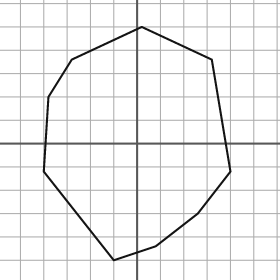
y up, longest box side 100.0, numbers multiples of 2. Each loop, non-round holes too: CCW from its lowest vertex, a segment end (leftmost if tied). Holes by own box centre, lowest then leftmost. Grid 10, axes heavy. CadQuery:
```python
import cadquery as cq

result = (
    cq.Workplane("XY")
    .moveTo(-10.0, -50.0)
    .lineTo(8.0, -44.0)
    .lineTo(26.0, -30.0)
    .lineTo(40.0, -12.0)
    .lineTo(32.0, 36.0)
    .lineTo(2.0, 50.0)
    .lineTo(-28.0, 36.0)
    .lineTo(-38.0, 20.0)
    .lineTo(-40.0, -12.0)
    .close()
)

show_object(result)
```